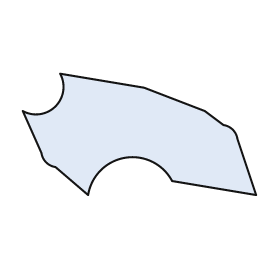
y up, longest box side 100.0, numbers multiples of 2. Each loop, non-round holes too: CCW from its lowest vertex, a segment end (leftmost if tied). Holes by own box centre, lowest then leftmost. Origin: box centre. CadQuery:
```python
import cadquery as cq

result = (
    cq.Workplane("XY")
    .moveTo(-22.0, -26.0)
    .threePointArc((-6.0, -10.0), (14.0, -20.0))
    .lineTo(50.0, -26.0)
    .lineTo(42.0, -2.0)
    .threePointArc((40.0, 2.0), (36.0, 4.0))
    .lineTo(28.0, 10.0)
    .lineTo(2.0, 20.0)
    .lineTo(-34.0, 26.0)
    .threePointArc((-36.0, 12.0), (-50.0, 10.0))
    .lineTo(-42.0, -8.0)
    .threePointArc((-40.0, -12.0), (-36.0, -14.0))
    .close()
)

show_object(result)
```